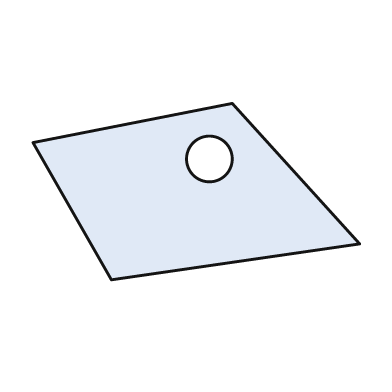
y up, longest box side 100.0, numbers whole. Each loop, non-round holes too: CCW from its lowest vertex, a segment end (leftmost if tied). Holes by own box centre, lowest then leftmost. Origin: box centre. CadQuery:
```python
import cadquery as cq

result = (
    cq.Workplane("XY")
    .moveTo(-26.0, -27.0)
    .lineTo(50.0, -16.0)
    .lineTo(11.0, 27.0)
    .lineTo(-50.0, 15.0)
    .close()
    .moveTo(4.0, 10.0)
    .circle(7.0)
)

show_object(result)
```